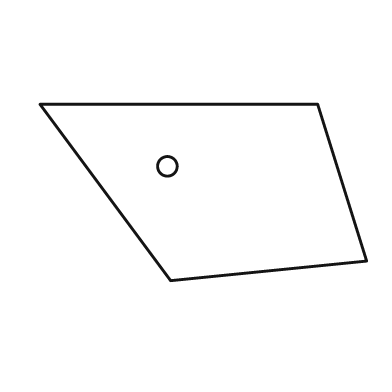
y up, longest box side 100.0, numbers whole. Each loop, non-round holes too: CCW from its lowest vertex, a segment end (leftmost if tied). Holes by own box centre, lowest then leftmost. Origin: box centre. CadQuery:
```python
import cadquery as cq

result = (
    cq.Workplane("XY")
    .moveTo(-10.0, -27.0)
    .lineTo(50.0, -21.0)
    .lineTo(35.0, 27.0)
    .lineTo(-50.0, 27.0)
    .close()
    .moveTo(-11.0, 8.0)
    .circle(3.0)
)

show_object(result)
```